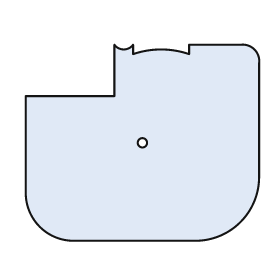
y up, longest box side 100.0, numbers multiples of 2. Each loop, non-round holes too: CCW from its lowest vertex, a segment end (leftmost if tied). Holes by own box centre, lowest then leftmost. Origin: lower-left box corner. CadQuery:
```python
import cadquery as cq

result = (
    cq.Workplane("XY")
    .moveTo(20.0, 0.0)
    .lineTo(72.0, 0.0)
    .threePointArc((92.0, 8.0), (100.0, 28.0))
    .lineTo(100.0, 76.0)
    .threePointArc((98.0, 82.0), (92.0, 84.0))
    .lineTo(70.0, 84.0)
    .lineTo(70.0, 80.0)
    .threePointArc((58.0, 82.0), (46.0, 80.0))
    .lineTo(46.0, 84.0)
    .threePointArc((42.0, 82.0), (38.0, 84.0))
    .lineTo(38.0, 62.0)
    .lineTo(0.0, 62.0)
    .lineTo(0.0, 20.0)
    .threePointArc((6.0, 6.0), (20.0, 0.0))
    .close()
    .moveTo(50.0, 42.0)
    .circle(2.0)
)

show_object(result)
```